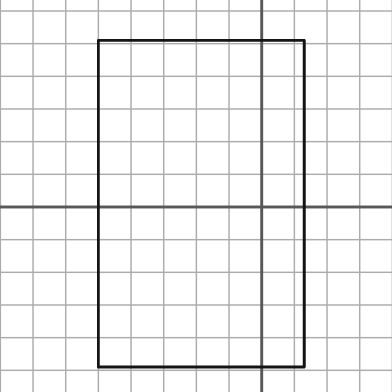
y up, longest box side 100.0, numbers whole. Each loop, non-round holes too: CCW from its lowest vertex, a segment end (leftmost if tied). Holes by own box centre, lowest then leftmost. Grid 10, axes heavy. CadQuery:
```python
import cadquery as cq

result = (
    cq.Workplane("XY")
    .moveTo(-50.0, -49.0)
    .lineTo(13.0, -49.0)
    .lineTo(13.0, 51.0)
    .lineTo(-50.0, 51.0)
    .close()
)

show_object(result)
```